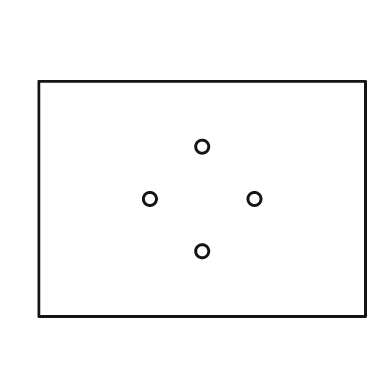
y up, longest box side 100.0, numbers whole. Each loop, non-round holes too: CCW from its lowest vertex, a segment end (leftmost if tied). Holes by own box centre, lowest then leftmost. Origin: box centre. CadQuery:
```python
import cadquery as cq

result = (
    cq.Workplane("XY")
    .moveTo(-50.0, -36.0)
    .lineTo(50.0, -36.0)
    .lineTo(50.0, 36.0)
    .lineTo(-50.0, 36.0)
    .close()
    .moveTo(0.0, -16.0)
    .circle(2.0)
    .moveTo(-16.0, 0.0)
    .circle(2.0)
    .moveTo(16.0, 0.0)
    .circle(2.0)
    .moveTo(0.0, 16.0)
    .circle(2.0)
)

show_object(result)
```